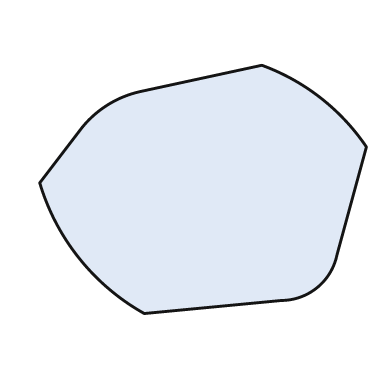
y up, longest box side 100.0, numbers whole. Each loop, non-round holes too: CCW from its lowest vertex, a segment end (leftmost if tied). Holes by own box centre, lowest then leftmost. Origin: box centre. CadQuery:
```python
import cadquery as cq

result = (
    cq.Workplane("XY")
    .moveTo(-18.0, -38.0)
    .lineTo(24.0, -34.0)
    .threePointArc((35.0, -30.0), (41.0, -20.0))
    .lineTo(50.0, 13.0)
    .threePointArc((36.0, 28.0), (18.0, 38.0))
    .lineTo(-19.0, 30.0)
    .threePointArc((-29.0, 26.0), (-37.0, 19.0))
    .lineTo(-50.0, 2.0)
    .threePointArc((-38.0, -21.0), (-18.0, -38.0))
    .close()
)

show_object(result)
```